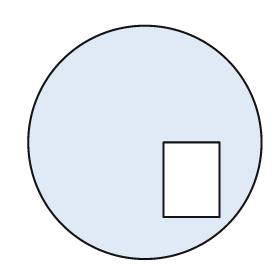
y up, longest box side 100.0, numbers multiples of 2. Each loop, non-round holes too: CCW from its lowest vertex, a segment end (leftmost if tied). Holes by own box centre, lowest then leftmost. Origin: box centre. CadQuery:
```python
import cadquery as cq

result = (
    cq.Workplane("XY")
    .moveTo(0.0, 0.0)
    .circle(50.0)
    .moveTo(8.0, -32.0)
    .lineTo(32.0, -32.0)
    .lineTo(32.0, 0.0)
    .lineTo(8.0, 0.0)
    .close()
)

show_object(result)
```